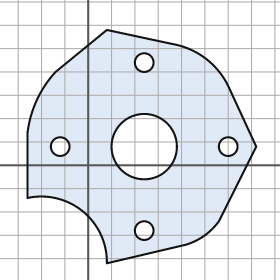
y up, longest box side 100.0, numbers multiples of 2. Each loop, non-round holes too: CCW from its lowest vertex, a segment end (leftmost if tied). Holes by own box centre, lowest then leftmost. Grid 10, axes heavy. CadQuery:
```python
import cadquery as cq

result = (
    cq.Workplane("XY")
    .moveTo(8.0, -42.0)
    .lineTo(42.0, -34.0)
    .threePointArc((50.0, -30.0), (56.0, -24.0))
    .lineTo(72.0, 8.0)
    .lineTo(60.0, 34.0)
    .threePointArc((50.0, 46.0), (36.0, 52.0))
    .lineTo(8.0, 58.0)
    .lineTo(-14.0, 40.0)
    .threePointArc((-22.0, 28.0), (-26.0, 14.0))
    .lineTo(-26.0, -14.0)
    .threePointArc((-2.0, -20.0), (8.0, -42.0))
    .close()
    .moveTo(24.0, -28.0)
    .circle(4.0)
    .moveTo(-12.0, 8.0)
    .circle(4.0)
    .moveTo(24.0, 8.0)
    .circle(14.0)
    .moveTo(60.0, 8.0)
    .circle(4.0)
    .moveTo(24.0, 44.0)
    .circle(4.0)
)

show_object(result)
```